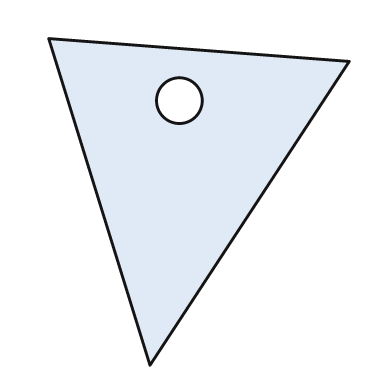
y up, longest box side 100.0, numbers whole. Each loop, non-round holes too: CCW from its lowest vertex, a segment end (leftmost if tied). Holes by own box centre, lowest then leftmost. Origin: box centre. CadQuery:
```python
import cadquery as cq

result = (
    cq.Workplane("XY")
    .moveTo(-15.0, -50.0)
    .lineTo(46.0, 43.0)
    .lineTo(-46.0, 50.0)
    .close()
    .moveTo(-6.0, 31.0)
    .circle(7.0)
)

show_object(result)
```